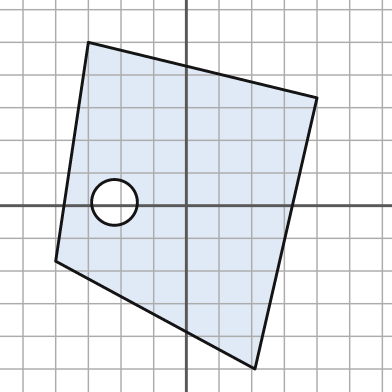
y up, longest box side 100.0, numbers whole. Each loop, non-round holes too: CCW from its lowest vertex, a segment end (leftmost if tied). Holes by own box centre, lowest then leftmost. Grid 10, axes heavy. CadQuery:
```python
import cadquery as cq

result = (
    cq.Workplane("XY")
    .moveTo(21.0, -50.0)
    .lineTo(40.0, 33.0)
    .lineTo(-30.0, 50.0)
    .lineTo(-40.0, -17.0)
    .close()
    .moveTo(-22.0, 1.0)
    .circle(7.0)
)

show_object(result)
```